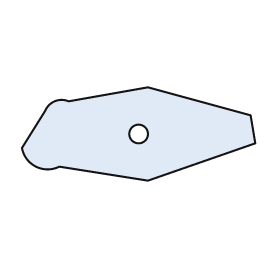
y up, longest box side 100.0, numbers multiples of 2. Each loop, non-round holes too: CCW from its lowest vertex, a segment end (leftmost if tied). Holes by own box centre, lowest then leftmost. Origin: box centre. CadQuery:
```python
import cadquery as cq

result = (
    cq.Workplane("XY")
    .moveTo(4.0, -20.0)
    .lineTo(50.0, -4.0)
    .lineTo(48.0, 8.0)
    .lineTo(4.0, 20.0)
    .lineTo(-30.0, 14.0)
    .threePointArc((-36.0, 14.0), (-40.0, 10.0))
    .lineTo(-50.0, -6.0)
    .threePointArc((-44.0, -14.0), (-34.0, -14.0))
    .close()
    .moveTo(0.0, 0.0)
    .circle(4.0)
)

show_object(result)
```